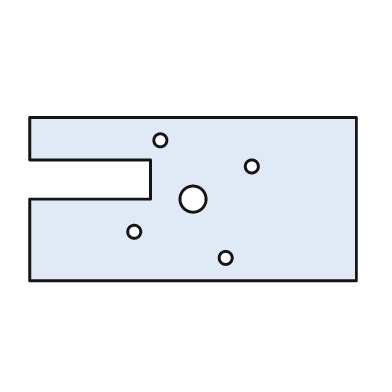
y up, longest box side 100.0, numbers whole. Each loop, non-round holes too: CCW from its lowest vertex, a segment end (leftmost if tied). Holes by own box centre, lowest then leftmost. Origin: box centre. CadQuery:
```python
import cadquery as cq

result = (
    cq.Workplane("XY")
    .moveTo(-50.0, -25.0)
    .lineTo(50.0, -25.0)
    .lineTo(50.0, 25.0)
    .lineTo(-50.0, 25.0)
    .lineTo(-50.0, 12.0)
    .lineTo(-13.0, 12.0)
    .lineTo(-13.0, 0.0)
    .lineTo(-50.0, 0.0)
    .close()
    .moveTo(10.0, -18.0)
    .circle(2.0)
    .moveTo(-18.0, -10.0)
    .circle(2.0)
    .moveTo(0.0, 0.0)
    .circle(4.0)
    .moveTo(18.0, 10.0)
    .circle(2.0)
    .moveTo(-10.0, 18.0)
    .circle(2.0)
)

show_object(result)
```